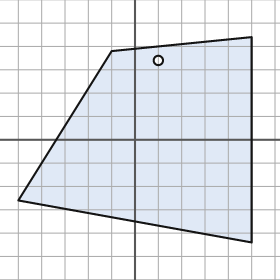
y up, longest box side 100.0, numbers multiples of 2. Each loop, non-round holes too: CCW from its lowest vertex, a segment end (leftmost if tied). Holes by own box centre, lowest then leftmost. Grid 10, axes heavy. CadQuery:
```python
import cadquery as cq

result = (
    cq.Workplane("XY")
    .moveTo(50.0, -44.0)
    .lineTo(50.0, 44.0)
    .lineTo(-10.0, 38.0)
    .lineTo(-50.0, -26.0)
    .close()
    .moveTo(10.0, 34.0)
    .circle(2.0)
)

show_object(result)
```